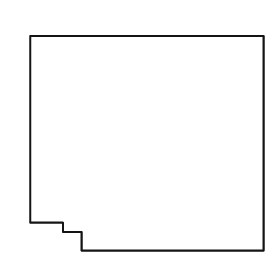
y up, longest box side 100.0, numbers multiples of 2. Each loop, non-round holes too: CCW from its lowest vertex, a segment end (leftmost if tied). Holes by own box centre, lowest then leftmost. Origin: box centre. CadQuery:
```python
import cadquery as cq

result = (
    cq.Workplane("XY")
    .moveTo(-28.0, -46.0)
    .lineTo(50.0, -46.0)
    .lineTo(50.0, 46.0)
    .lineTo(-50.0, 46.0)
    .lineTo(-50.0, -34.0)
    .lineTo(-36.0, -34.0)
    .lineTo(-36.0, -38.0)
    .lineTo(-28.0, -38.0)
    .close()
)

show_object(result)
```